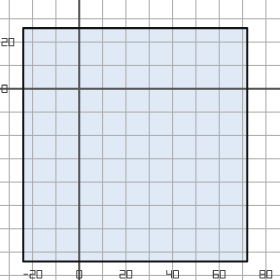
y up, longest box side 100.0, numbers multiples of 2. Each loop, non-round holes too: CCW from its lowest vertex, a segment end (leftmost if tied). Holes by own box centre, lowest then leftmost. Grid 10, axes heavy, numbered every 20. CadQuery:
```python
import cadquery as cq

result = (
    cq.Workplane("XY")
    .moveTo(-24.0, -74.0)
    .lineTo(72.0, -74.0)
    .lineTo(72.0, 26.0)
    .lineTo(-24.0, 26.0)
    .close()
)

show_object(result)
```